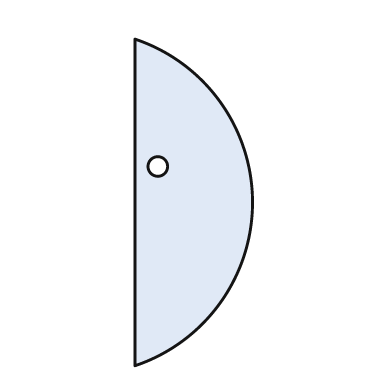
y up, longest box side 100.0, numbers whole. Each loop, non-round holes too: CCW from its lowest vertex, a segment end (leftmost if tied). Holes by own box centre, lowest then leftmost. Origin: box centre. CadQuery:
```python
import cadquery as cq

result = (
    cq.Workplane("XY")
    .moveTo(-18.0, -50.0)
    .threePointArc((18.0, 0.0), (-18.0, 50.0))
    .close()
    .moveTo(-11.0, 11.0)
    .circle(3.0)
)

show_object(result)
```